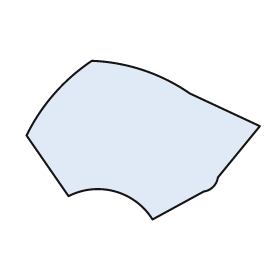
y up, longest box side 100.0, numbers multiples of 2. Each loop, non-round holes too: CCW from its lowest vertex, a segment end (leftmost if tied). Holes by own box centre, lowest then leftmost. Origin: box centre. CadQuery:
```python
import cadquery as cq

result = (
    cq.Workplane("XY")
    .moveTo(4.0, -34.0)
    .lineTo(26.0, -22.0)
    .threePointArc((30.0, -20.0), (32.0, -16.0))
    .lineTo(50.0, 6.0)
    .lineTo(20.0, 20.0)
    .threePointArc((0.0, 30.0), (-22.0, 34.0))
    .threePointArc((-38.0, 20.0), (-50.0, 2.0))
    .lineTo(-32.0, -24.0)
    .threePointArc((-12.0, -22.0), (4.0, -34.0))
    .close()
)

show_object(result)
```